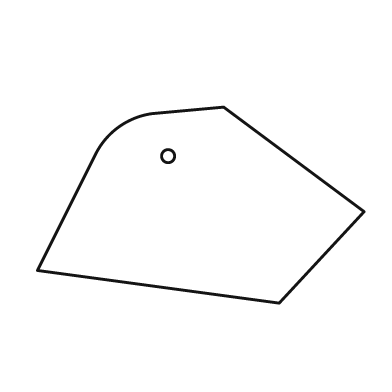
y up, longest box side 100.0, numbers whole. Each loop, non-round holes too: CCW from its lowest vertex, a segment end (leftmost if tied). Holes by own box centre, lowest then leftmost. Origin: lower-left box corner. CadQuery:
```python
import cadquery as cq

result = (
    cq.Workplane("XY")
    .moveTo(74.0, 0.0)
    .lineTo(100.0, 28.0)
    .lineTo(57.0, 60.0)
    .lineTo(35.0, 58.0)
    .threePointArc((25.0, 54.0), (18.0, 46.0))
    .lineTo(0.0, 10.0)
    .close()
    .moveTo(40.0, 45.0)
    .circle(2.0)
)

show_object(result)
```